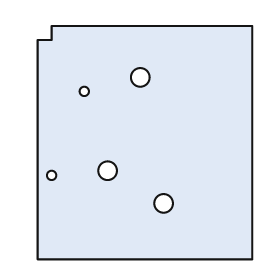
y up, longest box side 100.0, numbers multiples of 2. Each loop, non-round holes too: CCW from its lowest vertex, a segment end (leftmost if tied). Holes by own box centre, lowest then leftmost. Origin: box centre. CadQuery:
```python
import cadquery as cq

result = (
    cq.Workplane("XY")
    .moveTo(-46.0, -50.0)
    .lineTo(46.0, -50.0)
    .lineTo(46.0, 50.0)
    .lineTo(-40.0, 50.0)
    .lineTo(-40.0, 44.0)
    .lineTo(-46.0, 44.0)
    .close()
    .moveTo(8.0, -26.0)
    .circle(4.0)
    .moveTo(-40.0, -14.0)
    .circle(2.0)
    .moveTo(-16.0, -12.0)
    .circle(4.0)
    .moveTo(-26.0, 22.0)
    .circle(2.0)
    .moveTo(-2.0, 28.0)
    .circle(4.0)
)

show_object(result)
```